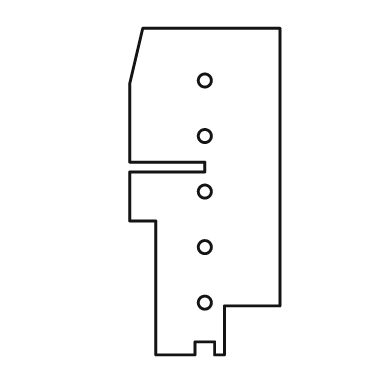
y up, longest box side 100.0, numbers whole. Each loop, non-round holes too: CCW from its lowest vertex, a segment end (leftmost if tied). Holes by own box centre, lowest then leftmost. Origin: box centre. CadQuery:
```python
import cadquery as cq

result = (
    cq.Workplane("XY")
    .moveTo(-15.0, -50.0)
    .lineTo(-3.0, -50.0)
    .lineTo(-3.0, -46.0)
    .lineTo(3.0, -46.0)
    .lineTo(3.0, -50.0)
    .lineTo(6.0, -50.0)
    .lineTo(6.0, -35.0)
    .lineTo(23.0, -35.0)
    .lineTo(23.0, 50.0)
    .lineTo(-19.0, 50.0)
    .lineTo(-23.0, 33.0)
    .lineTo(-23.0, 9.0)
    .lineTo(0.0, 9.0)
    .lineTo(0.0, 6.0)
    .lineTo(-23.0, 6.0)
    .lineTo(-23.0, -9.0)
    .lineTo(-15.0, -9.0)
    .close()
    .moveTo(0.0, -34.0)
    .circle(2.0)
    .moveTo(0.0, -17.0)
    .circle(2.0)
    .moveTo(0.0, 0.0)
    .circle(2.0)
    .moveTo(0.0, 17.0)
    .circle(2.0)
    .moveTo(0.0, 34.0)
    .circle(2.0)
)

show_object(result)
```